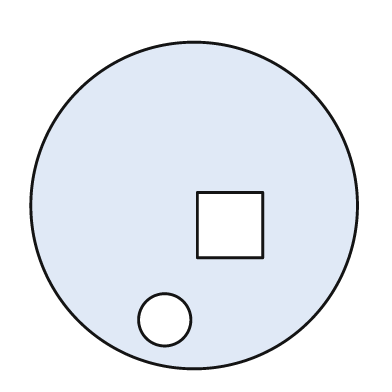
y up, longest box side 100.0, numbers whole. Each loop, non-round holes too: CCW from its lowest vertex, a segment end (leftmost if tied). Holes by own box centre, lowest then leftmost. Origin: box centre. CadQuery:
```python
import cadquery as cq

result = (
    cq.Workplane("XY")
    .moveTo(0.0, 0.0)
    .circle(50.0)
    .moveTo(-9.0, -35.0)
    .circle(8.0)
    .moveTo(1.0, -16.0)
    .lineTo(21.0, -16.0)
    .lineTo(21.0, 4.0)
    .lineTo(1.0, 4.0)
    .close()
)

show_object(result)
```